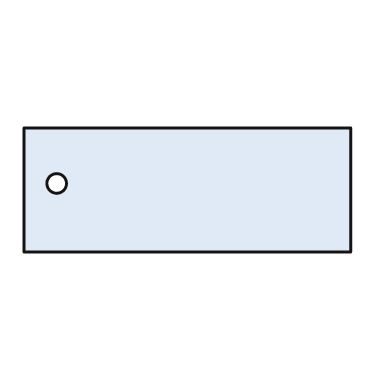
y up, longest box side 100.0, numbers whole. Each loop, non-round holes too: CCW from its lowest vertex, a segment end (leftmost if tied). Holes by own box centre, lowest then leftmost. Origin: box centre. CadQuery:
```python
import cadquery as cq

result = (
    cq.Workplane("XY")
    .moveTo(-50.0, -19.0)
    .lineTo(50.0, -19.0)
    .lineTo(50.0, 19.0)
    .lineTo(-50.0, 19.0)
    .close()
    .moveTo(-40.0, 2.0)
    .circle(3.0)
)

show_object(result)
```